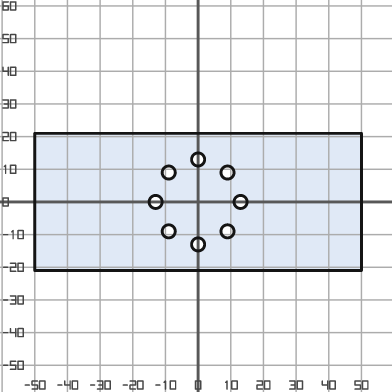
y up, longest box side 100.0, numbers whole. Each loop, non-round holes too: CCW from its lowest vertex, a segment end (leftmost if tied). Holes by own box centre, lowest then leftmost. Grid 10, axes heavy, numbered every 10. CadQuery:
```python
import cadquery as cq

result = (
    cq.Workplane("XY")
    .moveTo(-50.0, -21.0)
    .lineTo(50.0, -21.0)
    .lineTo(50.0, 21.0)
    .lineTo(-50.0, 21.0)
    .close()
    .moveTo(0.0, -13.0)
    .circle(2.0)
    .moveTo(-9.0, -9.0)
    .circle(2.0)
    .moveTo(9.0, -9.0)
    .circle(2.0)
    .moveTo(-13.0, 0.0)
    .circle(2.0)
    .moveTo(13.0, 0.0)
    .circle(2.0)
    .moveTo(-9.0, 9.0)
    .circle(2.0)
    .moveTo(9.0, 9.0)
    .circle(2.0)
    .moveTo(0.0, 13.0)
    .circle(2.0)
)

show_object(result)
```